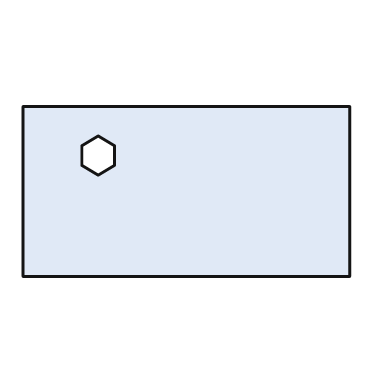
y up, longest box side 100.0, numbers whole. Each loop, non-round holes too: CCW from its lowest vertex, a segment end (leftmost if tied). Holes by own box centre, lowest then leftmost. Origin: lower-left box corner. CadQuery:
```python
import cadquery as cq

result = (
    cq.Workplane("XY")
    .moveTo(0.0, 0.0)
    .lineTo(100.0, 0.0)
    .lineTo(100.0, 52.0)
    .lineTo(0.0, 52.0)
    .close()
    .moveTo(23.0, 31.0)
    .lineTo(28.0, 34.0)
    .lineTo(28.0, 40.0)
    .lineTo(23.0, 43.0)
    .lineTo(18.0, 40.0)
    .lineTo(18.0, 34.0)
    .close()
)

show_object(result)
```